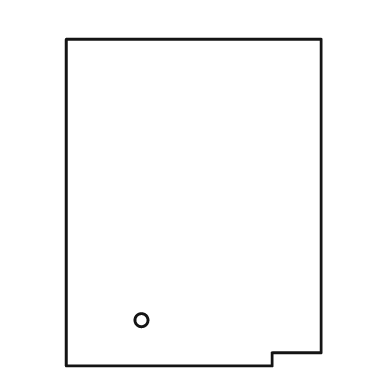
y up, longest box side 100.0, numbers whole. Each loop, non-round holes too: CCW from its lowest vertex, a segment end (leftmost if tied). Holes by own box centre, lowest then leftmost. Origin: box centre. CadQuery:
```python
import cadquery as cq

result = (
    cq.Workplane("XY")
    .moveTo(-39.0, -50.0)
    .lineTo(24.0, -50.0)
    .lineTo(24.0, -46.0)
    .lineTo(39.0, -46.0)
    .lineTo(39.0, 50.0)
    .lineTo(-39.0, 50.0)
    .close()
    .moveTo(-16.0, -36.0)
    .circle(2.0)
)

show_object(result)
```